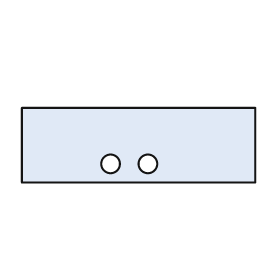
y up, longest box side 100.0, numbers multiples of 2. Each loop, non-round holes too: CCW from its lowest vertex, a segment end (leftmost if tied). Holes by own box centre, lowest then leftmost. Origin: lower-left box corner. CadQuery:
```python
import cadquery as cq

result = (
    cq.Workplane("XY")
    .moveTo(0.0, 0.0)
    .lineTo(100.0, 0.0)
    .lineTo(100.0, 32.0)
    .lineTo(0.0, 32.0)
    .close()
    .moveTo(38.0, 8.0)
    .circle(4.0)
    .moveTo(54.0, 8.0)
    .circle(4.0)
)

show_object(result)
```